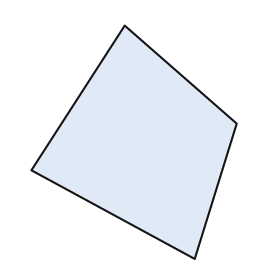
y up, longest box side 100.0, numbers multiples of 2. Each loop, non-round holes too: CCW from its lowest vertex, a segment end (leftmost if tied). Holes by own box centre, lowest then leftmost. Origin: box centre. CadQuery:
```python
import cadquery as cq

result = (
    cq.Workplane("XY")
    .moveTo(26.0, -50.0)
    .lineTo(44.0, 8.0)
    .lineTo(-4.0, 50.0)
    .lineTo(-44.0, -12.0)
    .close()
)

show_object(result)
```